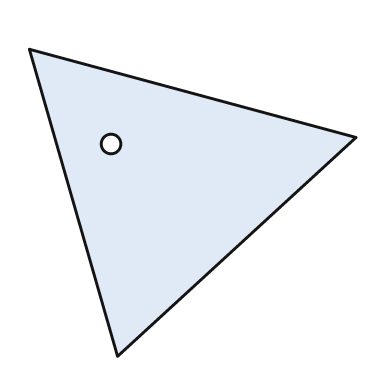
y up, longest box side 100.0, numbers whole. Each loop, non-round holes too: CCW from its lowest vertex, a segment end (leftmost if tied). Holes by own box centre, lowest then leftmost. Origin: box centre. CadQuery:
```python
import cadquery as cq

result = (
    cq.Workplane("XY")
    .moveTo(-23.0, -47.0)
    .lineTo(50.0, 20.0)
    .lineTo(-50.0, 47.0)
    .close()
    .moveTo(-25.0, 18.0)
    .circle(3.0)
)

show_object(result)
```